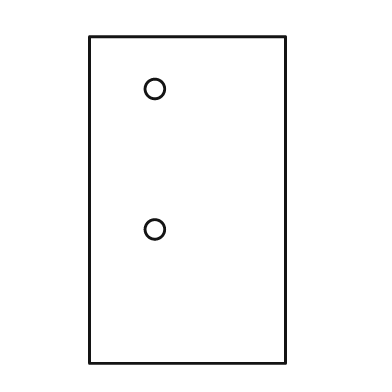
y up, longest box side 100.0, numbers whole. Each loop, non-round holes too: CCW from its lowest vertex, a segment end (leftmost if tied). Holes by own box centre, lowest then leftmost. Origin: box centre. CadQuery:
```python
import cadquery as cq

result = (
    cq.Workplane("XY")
    .moveTo(-30.0, -50.0)
    .lineTo(30.0, -50.0)
    .lineTo(30.0, 50.0)
    .lineTo(-30.0, 50.0)
    .close()
    .moveTo(-10.0, -9.0)
    .circle(3.0)
    .moveTo(-10.0, 34.0)
    .circle(3.0)
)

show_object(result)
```